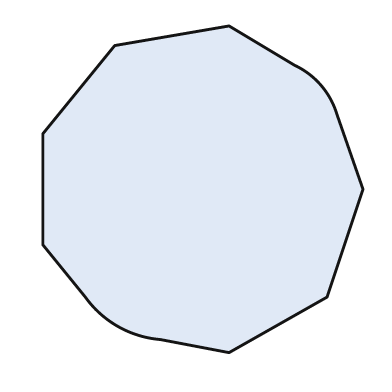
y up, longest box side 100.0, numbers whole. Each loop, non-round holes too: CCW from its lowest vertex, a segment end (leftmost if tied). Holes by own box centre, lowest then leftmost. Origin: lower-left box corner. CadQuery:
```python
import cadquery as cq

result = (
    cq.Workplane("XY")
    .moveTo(57.0, 0.0)
    .lineTo(87.0, 17.0)
    .lineTo(98.0, 50.0)
    .lineTo(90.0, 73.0)
    .threePointArc((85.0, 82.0), (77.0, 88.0))
    .lineTo(57.0, 100.0)
    .lineTo(22.0, 94.0)
    .lineTo(0.0, 67.0)
    .lineTo(0.0, 33.0)
    .lineTo(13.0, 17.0)
    .threePointArc((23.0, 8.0), (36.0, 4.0))
    .close()
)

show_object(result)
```